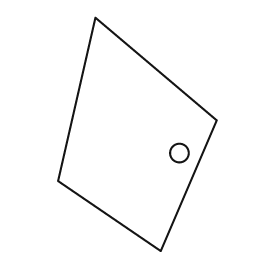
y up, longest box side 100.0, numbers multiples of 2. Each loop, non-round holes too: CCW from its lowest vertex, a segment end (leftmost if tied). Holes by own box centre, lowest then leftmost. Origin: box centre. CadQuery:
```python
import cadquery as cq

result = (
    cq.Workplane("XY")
    .moveTo(10.0, -50.0)
    .lineTo(34.0, 6.0)
    .lineTo(-18.0, 50.0)
    .lineTo(-34.0, -20.0)
    .close()
    .moveTo(18.0, -8.0)
    .circle(4.0)
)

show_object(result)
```